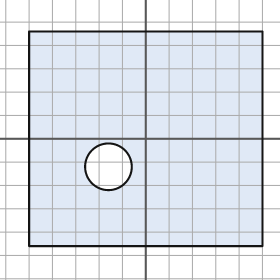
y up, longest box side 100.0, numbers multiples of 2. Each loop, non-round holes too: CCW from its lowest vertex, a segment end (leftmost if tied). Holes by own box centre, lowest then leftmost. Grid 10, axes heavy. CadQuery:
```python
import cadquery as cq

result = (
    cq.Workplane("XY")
    .moveTo(-50.0, -46.0)
    .lineTo(50.0, -46.0)
    .lineTo(50.0, 46.0)
    .lineTo(-50.0, 46.0)
    .close()
    .moveTo(-16.0, -12.0)
    .circle(10.0)
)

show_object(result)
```